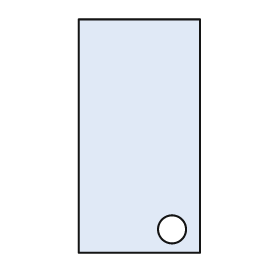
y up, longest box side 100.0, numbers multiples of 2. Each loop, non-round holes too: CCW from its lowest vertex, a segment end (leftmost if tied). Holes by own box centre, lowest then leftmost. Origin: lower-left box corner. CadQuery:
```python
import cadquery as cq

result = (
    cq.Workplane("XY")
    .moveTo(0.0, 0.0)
    .lineTo(52.0, 0.0)
    .lineTo(52.0, 100.0)
    .lineTo(0.0, 100.0)
    .close()
    .moveTo(40.0, 10.0)
    .circle(6.0)
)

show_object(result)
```